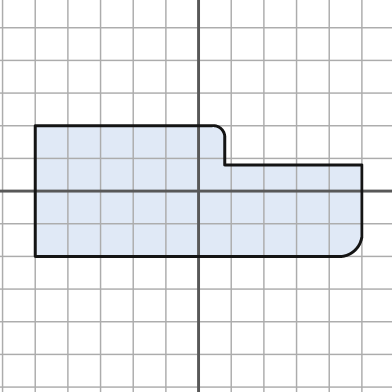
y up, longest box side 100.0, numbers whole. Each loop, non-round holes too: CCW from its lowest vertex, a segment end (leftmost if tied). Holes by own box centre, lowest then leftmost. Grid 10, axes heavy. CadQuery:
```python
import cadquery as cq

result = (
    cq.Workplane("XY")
    .moveTo(-50.0, -20.0)
    .lineTo(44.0, -20.0)
    .threePointArc((48.0, -18.0), (50.0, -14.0))
    .lineTo(50.0, 8.0)
    .lineTo(8.0, 8.0)
    .lineTo(8.0, 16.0)
    .threePointArc((7.0, 19.0), (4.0, 20.0))
    .lineTo(-50.0, 20.0)
    .close()
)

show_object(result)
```